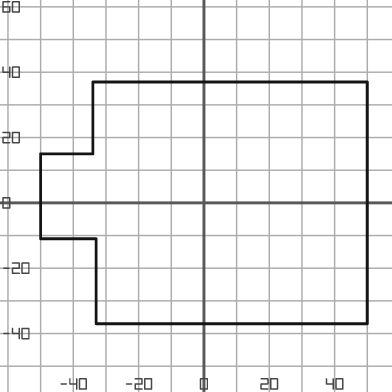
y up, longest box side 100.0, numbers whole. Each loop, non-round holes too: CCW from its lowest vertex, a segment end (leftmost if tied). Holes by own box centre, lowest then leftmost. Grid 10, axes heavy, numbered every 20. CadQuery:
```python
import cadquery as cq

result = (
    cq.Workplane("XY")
    .moveTo(-33.0, -37.0)
    .lineTo(50.0, -37.0)
    .lineTo(50.0, 37.0)
    .lineTo(-34.0, 37.0)
    .lineTo(-34.0, 15.0)
    .lineTo(-50.0, 15.0)
    .lineTo(-50.0, -11.0)
    .lineTo(-33.0, -11.0)
    .close()
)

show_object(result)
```